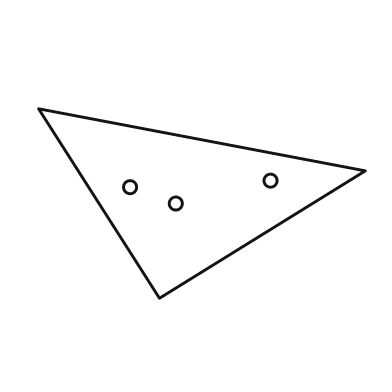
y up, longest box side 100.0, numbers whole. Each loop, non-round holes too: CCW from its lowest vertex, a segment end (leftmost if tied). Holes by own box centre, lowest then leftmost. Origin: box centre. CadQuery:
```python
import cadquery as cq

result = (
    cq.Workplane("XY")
    .moveTo(-13.0, -29.0)
    .lineTo(50.0, 10.0)
    .lineTo(-50.0, 29.0)
    .close()
    .moveTo(-8.0, 0.0)
    .circle(2.0)
    .moveTo(-22.0, 5.0)
    .circle(2.0)
    .moveTo(21.0, 7.0)
    .circle(2.0)
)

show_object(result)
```